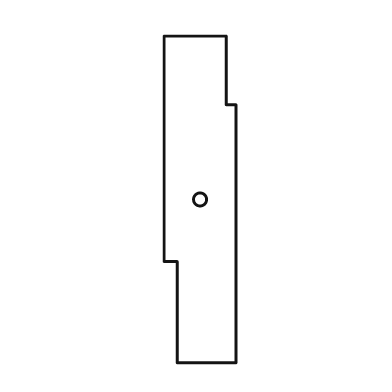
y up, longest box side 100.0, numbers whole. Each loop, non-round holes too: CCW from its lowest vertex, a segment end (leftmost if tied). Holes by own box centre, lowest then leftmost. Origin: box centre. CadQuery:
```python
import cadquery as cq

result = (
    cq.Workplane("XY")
    .moveTo(-7.0, -50.0)
    .lineTo(11.0, -50.0)
    .lineTo(11.0, 29.0)
    .lineTo(8.0, 29.0)
    .lineTo(8.0, 50.0)
    .lineTo(-11.0, 50.0)
    .lineTo(-11.0, -19.0)
    .lineTo(-7.0, -19.0)
    .close()
    .moveTo(0.0, 0.0)
    .circle(2.0)
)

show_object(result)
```